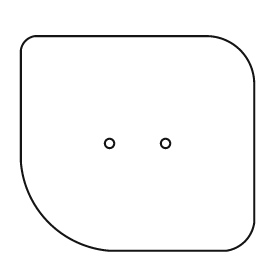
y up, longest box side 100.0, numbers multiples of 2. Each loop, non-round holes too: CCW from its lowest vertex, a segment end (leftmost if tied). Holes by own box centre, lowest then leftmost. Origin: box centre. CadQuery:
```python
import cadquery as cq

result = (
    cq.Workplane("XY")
    .moveTo(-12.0, -46.0)
    .lineTo(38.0, -46.0)
    .threePointArc((46.0, -42.0), (50.0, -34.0))
    .lineTo(50.0, 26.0)
    .threePointArc((44.0, 40.0), (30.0, 46.0))
    .lineTo(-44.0, 46.0)
    .threePointArc((-48.0, 44.0), (-50.0, 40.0))
    .lineTo(-50.0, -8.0)
    .threePointArc((-38.0, -34.0), (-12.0, -46.0))
    .close()
    .moveTo(-12.0, 0.0)
    .circle(2.0)
    .moveTo(12.0, 0.0)
    .circle(2.0)
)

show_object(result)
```